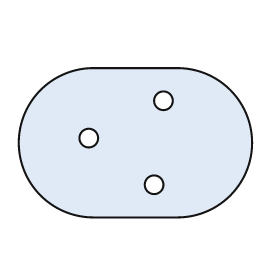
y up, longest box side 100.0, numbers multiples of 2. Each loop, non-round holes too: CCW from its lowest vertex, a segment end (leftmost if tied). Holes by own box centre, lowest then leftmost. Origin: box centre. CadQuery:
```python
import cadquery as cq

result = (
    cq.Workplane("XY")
    .moveTo(-18.0, -32.0)
    .lineTo(18.0, -32.0)
    .threePointArc((50.0, 0.0), (18.0, 32.0))
    .lineTo(-18.0, 32.0)
    .threePointArc((-50.0, 0.0), (-18.0, -32.0))
    .close()
    .moveTo(8.0, -18.0)
    .circle(4.0)
    .moveTo(-20.0, 2.0)
    .circle(4.0)
    .moveTo(12.0, 18.0)
    .circle(4.0)
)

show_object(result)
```